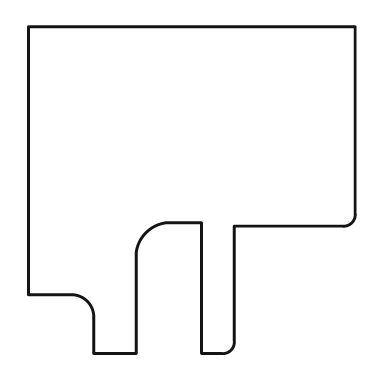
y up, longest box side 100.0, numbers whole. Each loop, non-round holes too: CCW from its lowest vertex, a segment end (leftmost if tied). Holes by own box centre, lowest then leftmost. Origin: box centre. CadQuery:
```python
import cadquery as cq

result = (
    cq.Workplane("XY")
    .moveTo(-30.0, -50.0)
    .lineTo(-17.0, -50.0)
    .lineTo(-17.0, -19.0)
    .threePointArc((-14.0, -13.0), (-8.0, -10.0))
    .lineTo(3.0, -10.0)
    .lineTo(3.0, -50.0)
    .lineTo(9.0, -50.0)
    .threePointArc((12.0, -49.0), (13.0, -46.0))
    .lineTo(13.0, -11.0)
    .lineTo(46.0, -11.0)
    .threePointArc((49.0, -10.0), (50.0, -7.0))
    .lineTo(50.0, 50.0)
    .lineTo(-50.0, 50.0)
    .lineTo(-50.0, -32.0)
    .lineTo(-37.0, -32.0)
    .threePointArc((-32.0, -34.0), (-30.0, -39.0))
    .close()
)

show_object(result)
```